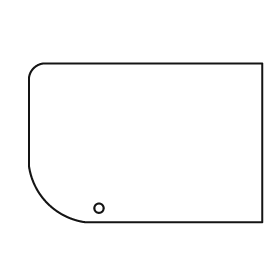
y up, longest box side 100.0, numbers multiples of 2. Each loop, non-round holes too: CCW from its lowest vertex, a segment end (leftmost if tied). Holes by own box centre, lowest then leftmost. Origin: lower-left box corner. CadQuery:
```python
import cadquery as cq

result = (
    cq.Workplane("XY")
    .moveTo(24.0, 0.0)
    .lineTo(100.0, 0.0)
    .lineTo(100.0, 68.0)
    .lineTo(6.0, 68.0)
    .threePointArc((2.0, 66.0), (0.0, 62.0))
    .lineTo(0.0, 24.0)
    .threePointArc((8.0, 8.0), (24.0, 0.0))
    .close()
    .moveTo(30.0, 6.0)
    .circle(2.0)
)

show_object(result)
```